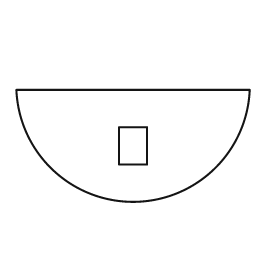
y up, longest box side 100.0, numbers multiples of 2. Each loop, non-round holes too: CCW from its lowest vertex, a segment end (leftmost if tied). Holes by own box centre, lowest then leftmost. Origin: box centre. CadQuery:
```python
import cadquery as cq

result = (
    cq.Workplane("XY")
    .moveTo(-50.0, 24.0)
    .threePointArc((0.0, -24.0), (50.0, 24.0))
    .close()
    .moveTo(-6.0, -8.0)
    .lineTo(6.0, -8.0)
    .lineTo(6.0, 8.0)
    .lineTo(-6.0, 8.0)
    .close()
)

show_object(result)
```